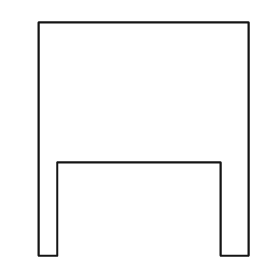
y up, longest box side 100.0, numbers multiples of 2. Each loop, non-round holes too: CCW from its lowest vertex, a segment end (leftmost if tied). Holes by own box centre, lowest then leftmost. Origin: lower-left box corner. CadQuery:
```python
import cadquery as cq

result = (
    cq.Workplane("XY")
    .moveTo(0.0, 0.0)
    .lineTo(8.0, 0.0)
    .lineTo(8.0, 40.0)
    .lineTo(78.0, 40.0)
    .lineTo(78.0, 0.0)
    .lineTo(90.0, 0.0)
    .lineTo(90.0, 100.0)
    .lineTo(0.0, 100.0)
    .close()
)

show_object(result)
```